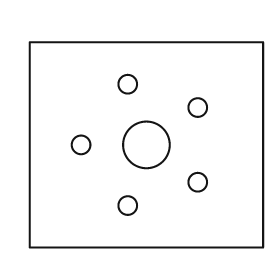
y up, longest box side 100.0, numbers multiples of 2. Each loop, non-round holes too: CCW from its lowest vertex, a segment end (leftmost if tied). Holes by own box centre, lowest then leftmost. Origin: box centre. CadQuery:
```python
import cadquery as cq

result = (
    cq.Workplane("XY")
    .moveTo(-50.0, -44.0)
    .lineTo(50.0, -44.0)
    .lineTo(50.0, 44.0)
    .lineTo(-50.0, 44.0)
    .close()
    .moveTo(-8.0, -26.0)
    .circle(4.0)
    .moveTo(22.0, -16.0)
    .circle(4.0)
    .moveTo(-28.0, 0.0)
    .circle(4.0)
    .moveTo(0.0, 0.0)
    .circle(10.0)
    .moveTo(22.0, 16.0)
    .circle(4.0)
    .moveTo(-8.0, 26.0)
    .circle(4.0)
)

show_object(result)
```